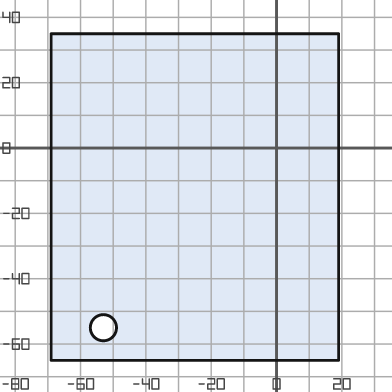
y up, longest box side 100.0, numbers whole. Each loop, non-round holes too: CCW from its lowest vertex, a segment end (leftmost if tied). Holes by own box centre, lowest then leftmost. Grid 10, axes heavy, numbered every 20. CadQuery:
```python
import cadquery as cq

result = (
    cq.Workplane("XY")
    .moveTo(-69.0, -65.0)
    .lineTo(19.0, -65.0)
    .lineTo(19.0, 35.0)
    .lineTo(-69.0, 35.0)
    .close()
    .moveTo(-53.0, -55.0)
    .circle(4.0)
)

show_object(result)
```